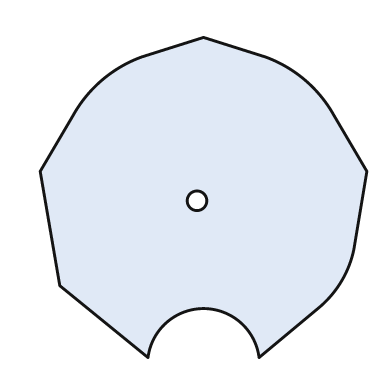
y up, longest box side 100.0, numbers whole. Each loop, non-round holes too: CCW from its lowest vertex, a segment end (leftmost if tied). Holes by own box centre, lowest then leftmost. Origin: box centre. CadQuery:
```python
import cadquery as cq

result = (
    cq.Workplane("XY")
    .moveTo(-17.0, -49.0)
    .threePointArc((0.0, -34.0), (17.0, -49.0))
    .lineTo(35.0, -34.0)
    .threePointArc((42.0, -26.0), (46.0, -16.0))
    .lineTo(50.0, 8.0)
    .lineTo(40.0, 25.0)
    .threePointArc((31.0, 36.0), (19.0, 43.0))
    .lineTo(0.0, 49.0)
    .lineTo(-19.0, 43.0)
    .threePointArc((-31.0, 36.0), (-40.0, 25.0))
    .lineTo(-50.0, 8.0)
    .lineTo(-44.0, -27.0)
    .close()
    .moveTo(-2.0, -1.0)
    .circle(3.0)
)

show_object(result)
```